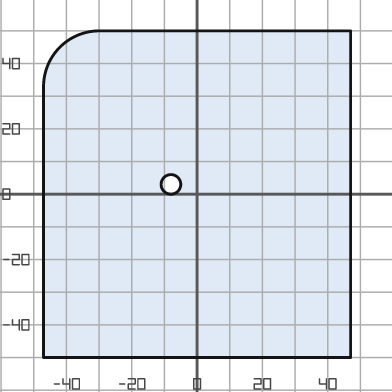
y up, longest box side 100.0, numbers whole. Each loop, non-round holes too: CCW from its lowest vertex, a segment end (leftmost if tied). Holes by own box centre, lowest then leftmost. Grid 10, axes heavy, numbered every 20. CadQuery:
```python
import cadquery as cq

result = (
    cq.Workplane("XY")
    .moveTo(-47.0, -50.0)
    .lineTo(47.0, -50.0)
    .lineTo(47.0, 50.0)
    .lineTo(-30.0, 50.0)
    .threePointArc((-42.0, 45.0), (-47.0, 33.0))
    .close()
    .moveTo(-8.0, 3.0)
    .circle(3.0)
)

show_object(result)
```